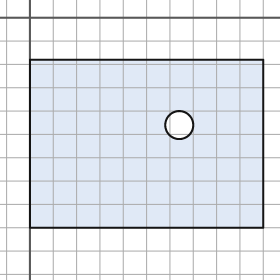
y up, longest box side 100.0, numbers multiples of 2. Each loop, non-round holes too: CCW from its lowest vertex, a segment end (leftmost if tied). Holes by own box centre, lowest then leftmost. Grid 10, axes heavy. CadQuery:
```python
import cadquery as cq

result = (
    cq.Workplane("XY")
    .moveTo(0.0, -90.0)
    .lineTo(100.0, -90.0)
    .lineTo(100.0, -18.0)
    .lineTo(0.0, -18.0)
    .close()
    .moveTo(64.0, -46.0)
    .circle(6.0)
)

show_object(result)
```